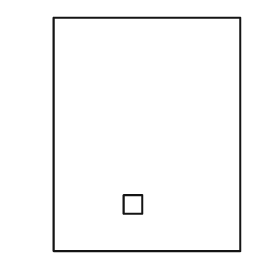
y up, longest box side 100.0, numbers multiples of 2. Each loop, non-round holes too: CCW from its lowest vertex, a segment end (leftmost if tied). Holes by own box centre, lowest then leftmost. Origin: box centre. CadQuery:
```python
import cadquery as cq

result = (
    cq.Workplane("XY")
    .moveTo(-40.0, -50.0)
    .lineTo(40.0, -50.0)
    .lineTo(40.0, 50.0)
    .lineTo(-40.0, 50.0)
    .close()
    .moveTo(-10.0, -34.0)
    .lineTo(-2.0, -34.0)
    .lineTo(-2.0, -26.0)
    .lineTo(-10.0, -26.0)
    .close()
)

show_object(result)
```